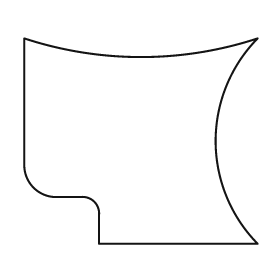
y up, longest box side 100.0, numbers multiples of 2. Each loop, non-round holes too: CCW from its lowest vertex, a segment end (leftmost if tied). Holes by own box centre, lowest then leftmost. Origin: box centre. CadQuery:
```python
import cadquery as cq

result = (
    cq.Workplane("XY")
    .moveTo(-18.0, -44.0)
    .lineTo(50.0, -44.0)
    .threePointArc((32.0, 0.0), (50.0, 44.0))
    .threePointArc((0.0, 36.0), (-50.0, 44.0))
    .lineTo(-50.0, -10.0)
    .threePointArc((-46.0, -20.0), (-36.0, -24.0))
    .lineTo(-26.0, -24.0)
    .threePointArc((-20.0, -26.0), (-18.0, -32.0))
    .close()
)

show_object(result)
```